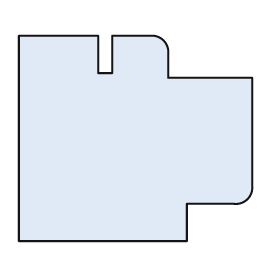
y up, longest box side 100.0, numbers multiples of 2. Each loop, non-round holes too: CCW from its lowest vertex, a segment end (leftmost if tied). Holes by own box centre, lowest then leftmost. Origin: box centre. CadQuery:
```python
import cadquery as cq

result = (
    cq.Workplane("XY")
    .moveTo(-50.0, -44.0)
    .lineTo(22.0, -44.0)
    .lineTo(22.0, -28.0)
    .lineTo(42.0, -28.0)
    .threePointArc((48.0, -26.0), (50.0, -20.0))
    .lineTo(50.0, 26.0)
    .lineTo(14.0, 26.0)
    .lineTo(14.0, 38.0)
    .threePointArc((12.0, 42.0), (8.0, 44.0))
    .lineTo(-10.0, 44.0)
    .lineTo(-10.0, 28.0)
    .lineTo(-16.0, 28.0)
    .lineTo(-16.0, 44.0)
    .lineTo(-50.0, 44.0)
    .close()
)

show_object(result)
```